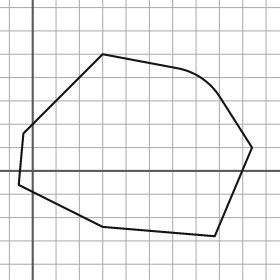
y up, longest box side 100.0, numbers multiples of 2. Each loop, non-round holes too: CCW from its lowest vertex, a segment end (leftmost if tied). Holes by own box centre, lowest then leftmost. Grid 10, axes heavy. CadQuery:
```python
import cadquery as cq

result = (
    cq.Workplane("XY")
    .moveTo(78.0, -28.0)
    .lineTo(94.0, 10.0)
    .lineTo(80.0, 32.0)
    .threePointArc((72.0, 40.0), (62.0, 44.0))
    .lineTo(30.0, 50.0)
    .lineTo(-4.0, 16.0)
    .lineTo(-6.0, -6.0)
    .lineTo(30.0, -24.0)
    .close()
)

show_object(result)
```